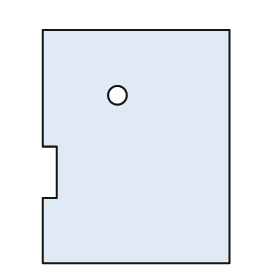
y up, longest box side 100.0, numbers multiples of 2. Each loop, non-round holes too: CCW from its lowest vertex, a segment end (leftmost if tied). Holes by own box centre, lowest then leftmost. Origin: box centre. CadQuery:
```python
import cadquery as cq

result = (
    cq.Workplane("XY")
    .moveTo(-40.0, -50.0)
    .lineTo(40.0, -50.0)
    .lineTo(40.0, 50.0)
    .lineTo(-40.0, 50.0)
    .lineTo(-40.0, 0.0)
    .lineTo(-34.0, 0.0)
    .lineTo(-34.0, -22.0)
    .lineTo(-40.0, -22.0)
    .close()
    .moveTo(-8.0, 22.0)
    .circle(4.0)
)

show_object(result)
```